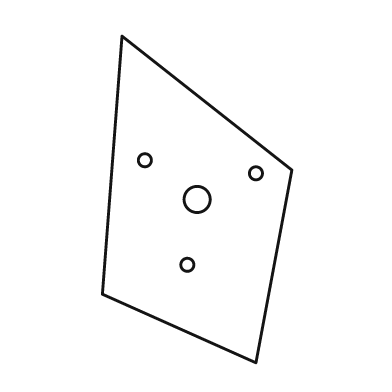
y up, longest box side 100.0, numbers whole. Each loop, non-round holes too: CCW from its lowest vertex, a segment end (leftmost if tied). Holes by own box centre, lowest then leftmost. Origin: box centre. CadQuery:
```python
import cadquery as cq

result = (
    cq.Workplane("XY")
    .moveTo(18.0, -50.0)
    .lineTo(29.0, 9.0)
    .lineTo(-23.0, 50.0)
    .lineTo(-29.0, -29.0)
    .close()
    .moveTo(-3.0, -20.0)
    .circle(2.0)
    .moveTo(0.0, 0.0)
    .circle(4.0)
    .moveTo(18.0, 8.0)
    .circle(2.0)
    .moveTo(-16.0, 12.0)
    .circle(2.0)
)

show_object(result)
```